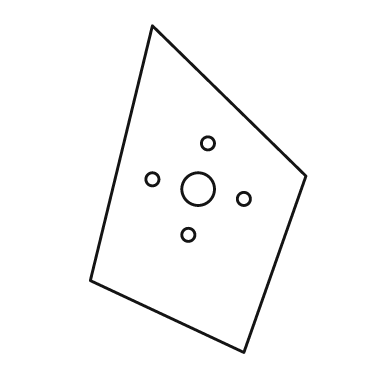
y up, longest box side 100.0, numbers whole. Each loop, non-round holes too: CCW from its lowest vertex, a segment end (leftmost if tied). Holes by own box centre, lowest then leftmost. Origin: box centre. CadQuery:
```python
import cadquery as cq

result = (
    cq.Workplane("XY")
    .moveTo(14.0, -50.0)
    .lineTo(33.0, 4.0)
    .lineTo(-14.0, 50.0)
    .lineTo(-33.0, -28.0)
    .close()
    .moveTo(-3.0, -14.0)
    .circle(2.0)
    .moveTo(14.0, -3.0)
    .circle(2.0)
    .moveTo(0.0, 0.0)
    .circle(5.0)
    .moveTo(-14.0, 3.0)
    .circle(2.0)
    .moveTo(3.0, 14.0)
    .circle(2.0)
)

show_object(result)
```